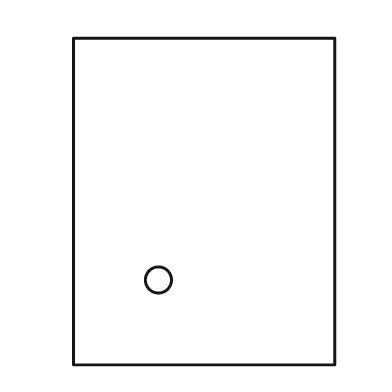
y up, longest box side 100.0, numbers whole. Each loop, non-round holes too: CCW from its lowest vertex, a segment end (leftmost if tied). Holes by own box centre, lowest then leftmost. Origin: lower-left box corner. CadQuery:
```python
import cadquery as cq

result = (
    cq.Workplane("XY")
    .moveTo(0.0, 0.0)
    .lineTo(80.0, 0.0)
    .lineTo(80.0, 100.0)
    .lineTo(0.0, 100.0)
    .close()
    .moveTo(26.0, 26.0)
    .circle(4.0)
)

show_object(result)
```